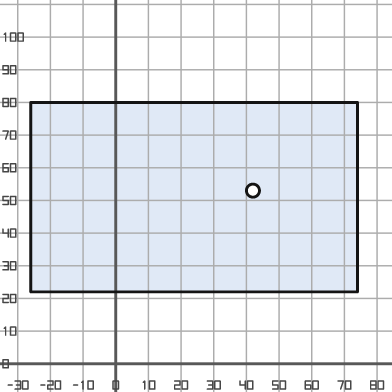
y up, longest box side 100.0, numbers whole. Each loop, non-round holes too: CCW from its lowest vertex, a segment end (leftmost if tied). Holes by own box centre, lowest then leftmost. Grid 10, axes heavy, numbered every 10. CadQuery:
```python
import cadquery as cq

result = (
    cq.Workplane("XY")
    .moveTo(-26.0, 22.0)
    .lineTo(74.0, 22.0)
    .lineTo(74.0, 80.0)
    .lineTo(-26.0, 80.0)
    .close()
    .moveTo(42.0, 53.0)
    .circle(2.0)
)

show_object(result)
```